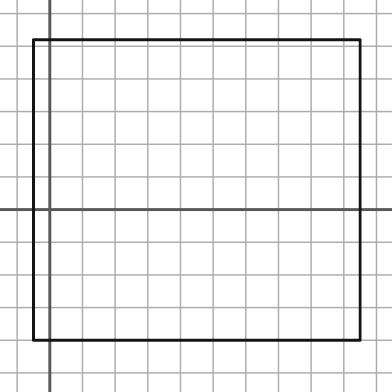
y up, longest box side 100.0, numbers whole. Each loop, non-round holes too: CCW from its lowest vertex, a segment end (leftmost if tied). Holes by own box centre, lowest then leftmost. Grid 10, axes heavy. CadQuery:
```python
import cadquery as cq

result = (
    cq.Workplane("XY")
    .moveTo(-5.0, -40.0)
    .lineTo(95.0, -40.0)
    .lineTo(95.0, 52.0)
    .lineTo(-5.0, 52.0)
    .close()
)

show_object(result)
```